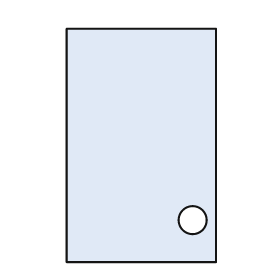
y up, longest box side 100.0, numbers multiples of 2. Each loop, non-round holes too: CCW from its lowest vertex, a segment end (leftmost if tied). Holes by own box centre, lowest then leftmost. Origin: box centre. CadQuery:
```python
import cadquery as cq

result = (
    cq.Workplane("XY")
    .moveTo(-32.0, -50.0)
    .lineTo(32.0, -50.0)
    .lineTo(32.0, 50.0)
    .lineTo(-32.0, 50.0)
    .close()
    .moveTo(22.0, -32.0)
    .circle(6.0)
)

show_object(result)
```